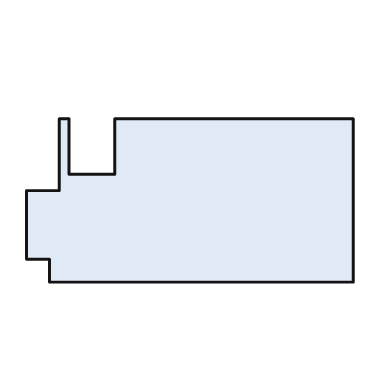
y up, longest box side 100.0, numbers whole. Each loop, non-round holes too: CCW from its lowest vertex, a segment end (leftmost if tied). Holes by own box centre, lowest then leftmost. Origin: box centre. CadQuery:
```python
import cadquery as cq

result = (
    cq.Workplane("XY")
    .moveTo(-43.0, -25.0)
    .lineTo(50.0, -25.0)
    .lineTo(50.0, 25.0)
    .lineTo(-23.0, 25.0)
    .lineTo(-23.0, 8.0)
    .lineTo(-37.0, 8.0)
    .lineTo(-37.0, 25.0)
    .lineTo(-40.0, 25.0)
    .lineTo(-40.0, 3.0)
    .lineTo(-50.0, 3.0)
    .lineTo(-50.0, -18.0)
    .lineTo(-43.0, -18.0)
    .close()
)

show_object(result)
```